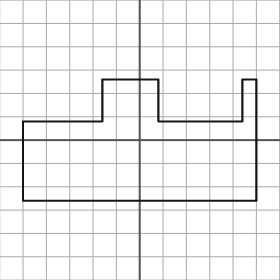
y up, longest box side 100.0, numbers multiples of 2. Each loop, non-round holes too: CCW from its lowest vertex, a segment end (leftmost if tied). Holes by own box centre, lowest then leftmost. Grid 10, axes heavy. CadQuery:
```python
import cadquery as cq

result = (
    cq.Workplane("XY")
    .moveTo(-50.0, -26.0)
    .lineTo(50.0, -26.0)
    .lineTo(50.0, 26.0)
    .lineTo(44.0, 26.0)
    .lineTo(44.0, 8.0)
    .lineTo(8.0, 8.0)
    .lineTo(8.0, 26.0)
    .lineTo(-16.0, 26.0)
    .lineTo(-16.0, 8.0)
    .lineTo(-50.0, 8.0)
    .close()
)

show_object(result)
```